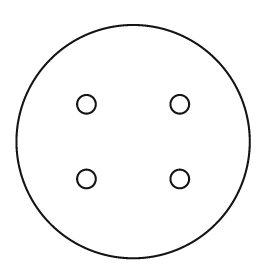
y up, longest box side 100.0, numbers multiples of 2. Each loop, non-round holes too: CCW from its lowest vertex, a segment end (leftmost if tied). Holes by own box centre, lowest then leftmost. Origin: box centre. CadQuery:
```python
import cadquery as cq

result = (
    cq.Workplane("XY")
    .moveTo(0.0, 0.0)
    .circle(50.0)
    .moveTo(-20.0, -16.0)
    .circle(4.0)
    .moveTo(20.0, -16.0)
    .circle(4.0)
    .moveTo(-20.0, 16.0)
    .circle(4.0)
    .moveTo(20.0, 16.0)
    .circle(4.0)
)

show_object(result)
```